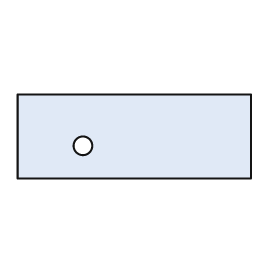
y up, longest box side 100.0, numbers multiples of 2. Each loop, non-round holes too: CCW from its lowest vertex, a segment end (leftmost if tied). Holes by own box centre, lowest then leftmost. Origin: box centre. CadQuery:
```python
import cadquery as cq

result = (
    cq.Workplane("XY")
    .moveTo(-50.0, -18.0)
    .lineTo(50.0, -18.0)
    .lineTo(50.0, 18.0)
    .lineTo(-50.0, 18.0)
    .close()
    .moveTo(-22.0, -4.0)
    .circle(4.0)
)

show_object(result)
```